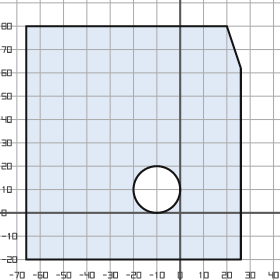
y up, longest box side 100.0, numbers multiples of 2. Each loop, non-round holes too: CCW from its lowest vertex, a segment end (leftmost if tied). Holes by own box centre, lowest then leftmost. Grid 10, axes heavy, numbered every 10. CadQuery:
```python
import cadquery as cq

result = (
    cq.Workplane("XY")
    .moveTo(-66.0, -20.0)
    .lineTo(26.0, -20.0)
    .lineTo(26.0, 62.0)
    .lineTo(20.0, 80.0)
    .lineTo(-66.0, 80.0)
    .close()
    .moveTo(-10.0, 10.0)
    .circle(10.0)
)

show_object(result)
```